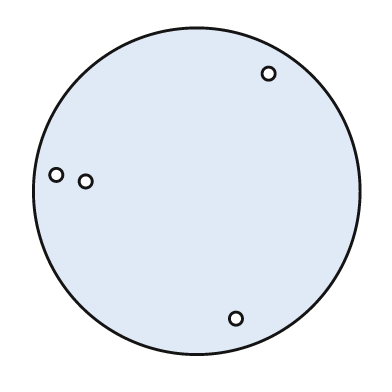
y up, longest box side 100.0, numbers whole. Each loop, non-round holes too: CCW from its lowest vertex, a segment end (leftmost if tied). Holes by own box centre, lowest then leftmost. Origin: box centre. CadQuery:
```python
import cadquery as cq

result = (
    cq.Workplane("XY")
    .moveTo(0.0, 0.0)
    .circle(50.0)
    .moveTo(12.0, -39.0)
    .circle(2.0)
    .moveTo(-34.0, 3.0)
    .circle(2.0)
    .moveTo(-43.0, 5.0)
    .circle(2.0)
    .moveTo(22.0, 36.0)
    .circle(2.0)
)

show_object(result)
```